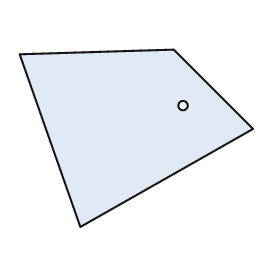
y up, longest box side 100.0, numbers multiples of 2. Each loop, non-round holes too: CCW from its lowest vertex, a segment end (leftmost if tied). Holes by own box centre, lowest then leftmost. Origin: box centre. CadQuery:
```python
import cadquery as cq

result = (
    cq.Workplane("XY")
    .moveTo(-24.0, -38.0)
    .lineTo(50.0, 4.0)
    .lineTo(16.0, 38.0)
    .lineTo(-50.0, 36.0)
    .close()
    .moveTo(20.0, 14.0)
    .circle(2.0)
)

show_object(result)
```